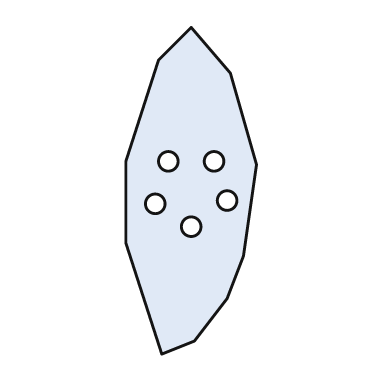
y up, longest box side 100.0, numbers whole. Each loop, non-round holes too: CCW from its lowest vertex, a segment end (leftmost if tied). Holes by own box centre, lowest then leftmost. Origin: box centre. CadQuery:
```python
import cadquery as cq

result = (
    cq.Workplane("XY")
    .moveTo(-9.0, -50.0)
    .lineTo(1.0, -46.0)
    .lineTo(11.0, -33.0)
    .lineTo(16.0, -20.0)
    .lineTo(20.0, 8.0)
    .lineTo(12.0, 36.0)
    .lineTo(0.0, 50.0)
    .lineTo(-10.0, 40.0)
    .lineTo(-20.0, 9.0)
    .lineTo(-20.0, -16.0)
    .close()
    .moveTo(0.0, -11.0)
    .circle(3.0)
    .moveTo(-11.0, -4.0)
    .circle(3.0)
    .moveTo(11.0, -3.0)
    .circle(3.0)
    .moveTo(-7.0, 9.0)
    .circle(3.0)
    .moveTo(7.0, 9.0)
    .circle(3.0)
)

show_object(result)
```